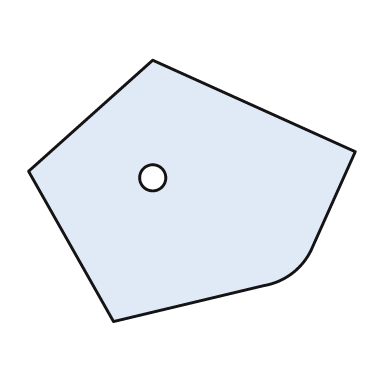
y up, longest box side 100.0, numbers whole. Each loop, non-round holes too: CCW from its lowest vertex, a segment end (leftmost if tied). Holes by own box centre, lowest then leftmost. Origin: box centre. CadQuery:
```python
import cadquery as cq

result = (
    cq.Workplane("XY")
    .moveTo(-24.0, -40.0)
    .lineTo(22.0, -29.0)
    .threePointArc((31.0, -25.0), (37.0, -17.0))
    .lineTo(50.0, 12.0)
    .lineTo(-12.0, 40.0)
    .lineTo(-50.0, 6.0)
    .close()
    .moveTo(-12.0, 4.0)
    .circle(4.0)
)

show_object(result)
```